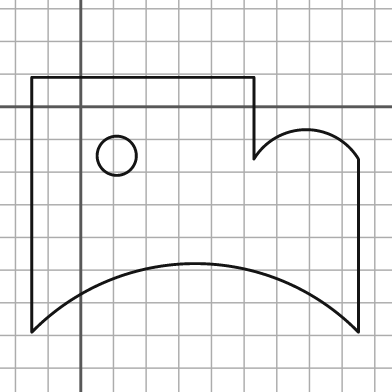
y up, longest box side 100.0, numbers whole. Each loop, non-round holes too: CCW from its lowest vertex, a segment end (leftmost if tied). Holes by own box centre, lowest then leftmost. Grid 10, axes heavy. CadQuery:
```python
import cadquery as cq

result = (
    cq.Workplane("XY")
    .moveTo(-15.0, -69.0)
    .threePointArc((35.0, -48.0), (85.0, -69.0))
    .lineTo(85.0, -16.0)
    .threePointArc((69.0, -7.0), (53.0, -16.0))
    .lineTo(53.0, 9.0)
    .lineTo(-15.0, 9.0)
    .close()
    .moveTo(11.0, -15.0)
    .circle(6.0)
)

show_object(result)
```